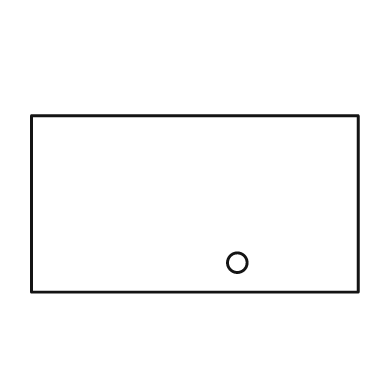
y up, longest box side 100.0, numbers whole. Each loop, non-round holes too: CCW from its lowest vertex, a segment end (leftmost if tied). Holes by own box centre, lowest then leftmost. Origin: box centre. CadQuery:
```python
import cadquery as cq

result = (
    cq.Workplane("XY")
    .moveTo(-50.0, -27.0)
    .lineTo(50.0, -27.0)
    .lineTo(50.0, 27.0)
    .lineTo(-50.0, 27.0)
    .close()
    .moveTo(13.0, -18.0)
    .circle(3.0)
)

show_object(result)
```